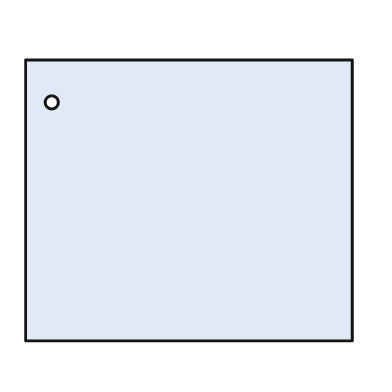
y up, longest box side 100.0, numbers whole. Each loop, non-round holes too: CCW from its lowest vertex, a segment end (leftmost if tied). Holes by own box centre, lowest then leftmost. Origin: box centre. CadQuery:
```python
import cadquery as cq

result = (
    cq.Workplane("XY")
    .moveTo(-50.0, -43.0)
    .lineTo(50.0, -43.0)
    .lineTo(50.0, 43.0)
    .lineTo(-50.0, 43.0)
    .close()
    .moveTo(-42.0, 30.0)
    .circle(2.0)
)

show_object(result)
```